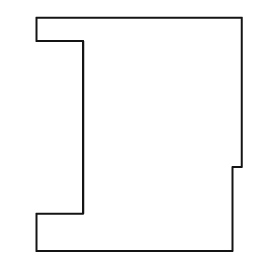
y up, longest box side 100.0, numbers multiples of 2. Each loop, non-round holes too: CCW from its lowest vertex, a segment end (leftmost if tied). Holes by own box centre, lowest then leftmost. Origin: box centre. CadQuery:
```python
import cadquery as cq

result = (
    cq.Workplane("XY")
    .moveTo(-44.0, -50.0)
    .lineTo(40.0, -50.0)
    .lineTo(40.0, -14.0)
    .lineTo(44.0, -14.0)
    .lineTo(44.0, 50.0)
    .lineTo(-44.0, 50.0)
    .lineTo(-44.0, 40.0)
    .lineTo(-24.0, 40.0)
    .lineTo(-24.0, -34.0)
    .lineTo(-44.0, -34.0)
    .close()
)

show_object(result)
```